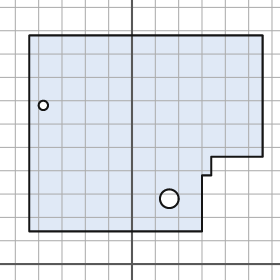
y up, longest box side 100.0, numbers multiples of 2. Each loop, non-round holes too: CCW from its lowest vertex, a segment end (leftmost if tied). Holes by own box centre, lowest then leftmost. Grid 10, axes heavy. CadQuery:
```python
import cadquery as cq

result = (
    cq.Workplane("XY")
    .moveTo(-44.0, 14.0)
    .lineTo(30.0, 14.0)
    .lineTo(30.0, 38.0)
    .lineTo(34.0, 38.0)
    .lineTo(34.0, 46.0)
    .lineTo(56.0, 46.0)
    .lineTo(56.0, 98.0)
    .lineTo(-44.0, 98.0)
    .close()
    .moveTo(16.0, 28.0)
    .circle(4.0)
    .moveTo(-38.0, 68.0)
    .circle(2.0)
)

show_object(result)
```